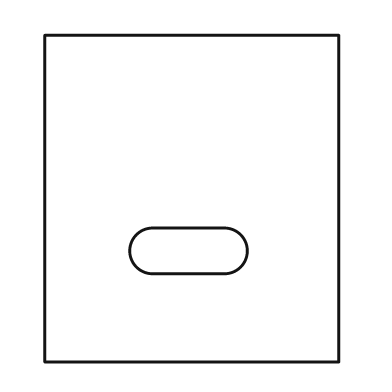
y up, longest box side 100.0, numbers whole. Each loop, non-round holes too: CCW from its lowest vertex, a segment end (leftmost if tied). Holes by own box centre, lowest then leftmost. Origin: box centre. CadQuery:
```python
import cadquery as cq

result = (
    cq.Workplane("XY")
    .moveTo(-45.0, -50.0)
    .lineTo(45.0, -50.0)
    .lineTo(45.0, 50.0)
    .lineTo(-45.0, 50.0)
    .close()
    .moveTo(-12.0, -23.0)
    .lineTo(10.0, -23.0)
    .threePointArc((17.0, -16.0), (10.0, -9.0))
    .lineTo(-12.0, -9.0)
    .threePointArc((-19.0, -16.0), (-12.0, -23.0))
    .close()
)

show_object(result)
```